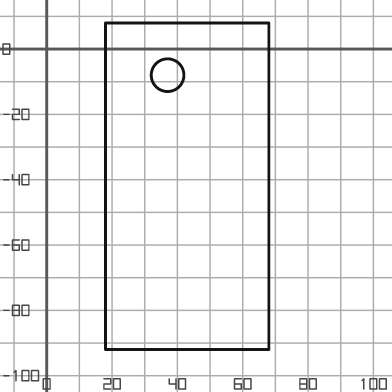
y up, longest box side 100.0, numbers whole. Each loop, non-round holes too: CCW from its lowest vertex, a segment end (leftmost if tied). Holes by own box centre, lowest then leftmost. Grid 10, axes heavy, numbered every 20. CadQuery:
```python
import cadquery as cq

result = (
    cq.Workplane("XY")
    .moveTo(18.0, -92.0)
    .lineTo(68.0, -92.0)
    .lineTo(68.0, 8.0)
    .lineTo(18.0, 8.0)
    .close()
    .moveTo(37.0, -8.0)
    .circle(5.0)
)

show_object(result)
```